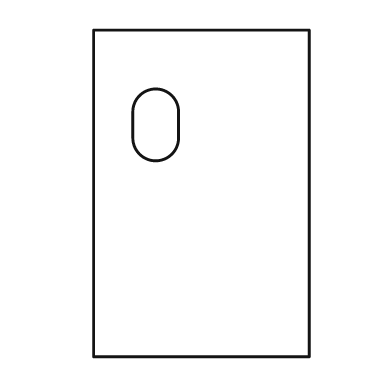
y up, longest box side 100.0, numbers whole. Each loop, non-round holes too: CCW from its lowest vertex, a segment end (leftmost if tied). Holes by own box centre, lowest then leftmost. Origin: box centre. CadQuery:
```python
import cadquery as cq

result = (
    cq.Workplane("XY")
    .moveTo(-33.0, -50.0)
    .lineTo(33.0, -50.0)
    .lineTo(33.0, 50.0)
    .lineTo(-33.0, 50.0)
    .close()
    .moveTo(-21.0, 17.0)
    .threePointArc((-14.0, 10.0), (-7.0, 17.0))
    .lineTo(-7.0, 25.0)
    .threePointArc((-14.0, 32.0), (-21.0, 25.0))
    .close()
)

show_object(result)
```